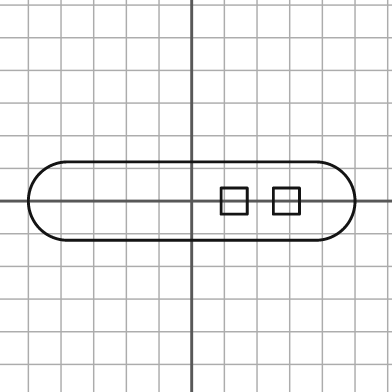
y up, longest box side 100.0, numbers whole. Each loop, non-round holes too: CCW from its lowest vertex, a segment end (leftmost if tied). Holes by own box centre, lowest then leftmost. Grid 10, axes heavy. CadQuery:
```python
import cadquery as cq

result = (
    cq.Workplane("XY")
    .moveTo(-38.0, -12.0)
    .lineTo(38.0, -12.0)
    .threePointArc((50.0, 0.0), (38.0, 12.0))
    .lineTo(-38.0, 12.0)
    .threePointArc((-50.0, 0.0), (-38.0, -12.0))
    .close()
    .moveTo(9.0, -4.0)
    .lineTo(17.0, -4.0)
    .lineTo(17.0, 4.0)
    .lineTo(9.0, 4.0)
    .close()
    .moveTo(25.0, -4.0)
    .lineTo(33.0, -4.0)
    .lineTo(33.0, 4.0)
    .lineTo(25.0, 4.0)
    .close()
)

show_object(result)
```